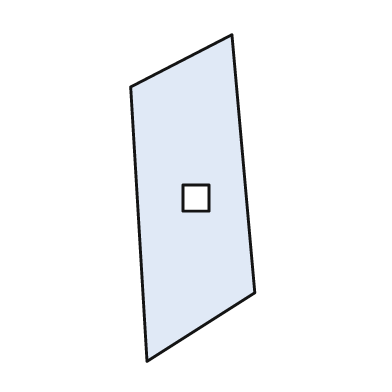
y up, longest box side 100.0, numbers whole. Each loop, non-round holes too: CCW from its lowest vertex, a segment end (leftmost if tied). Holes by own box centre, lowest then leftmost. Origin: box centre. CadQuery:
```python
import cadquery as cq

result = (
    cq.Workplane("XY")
    .moveTo(-14.0, -50.0)
    .lineTo(19.0, -29.0)
    .lineTo(12.0, 50.0)
    .lineTo(-19.0, 34.0)
    .close()
    .moveTo(-3.0, -4.0)
    .lineTo(5.0, -4.0)
    .lineTo(5.0, 4.0)
    .lineTo(-3.0, 4.0)
    .close()
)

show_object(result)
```